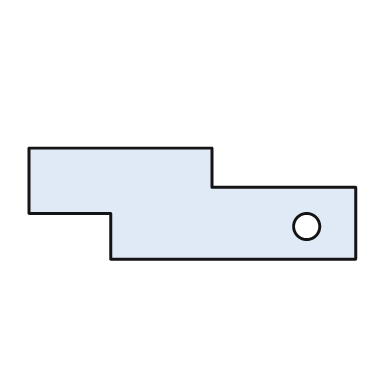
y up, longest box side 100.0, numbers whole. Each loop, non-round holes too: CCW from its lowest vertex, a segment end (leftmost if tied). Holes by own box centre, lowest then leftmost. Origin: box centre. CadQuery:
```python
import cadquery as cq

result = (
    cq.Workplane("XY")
    .moveTo(-25.0, -17.0)
    .lineTo(50.0, -17.0)
    .lineTo(50.0, 5.0)
    .lineTo(6.0, 5.0)
    .lineTo(6.0, 17.0)
    .lineTo(-50.0, 17.0)
    .lineTo(-50.0, -3.0)
    .lineTo(-25.0, -3.0)
    .close()
    .moveTo(35.0, -7.0)
    .circle(4.0)
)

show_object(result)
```